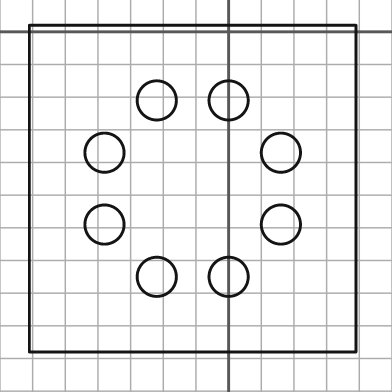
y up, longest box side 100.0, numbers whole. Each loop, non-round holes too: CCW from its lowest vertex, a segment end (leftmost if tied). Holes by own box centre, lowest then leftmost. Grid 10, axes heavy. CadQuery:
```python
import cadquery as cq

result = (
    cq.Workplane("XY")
    .moveTo(-61.0, -98.0)
    .lineTo(39.0, -98.0)
    .lineTo(39.0, 2.0)
    .lineTo(-61.0, 2.0)
    .close()
    .moveTo(-22.0, -75.0)
    .circle(6.0)
    .moveTo(0.0, -75.0)
    .circle(6.0)
    .moveTo(-38.0, -59.0)
    .circle(6.0)
    .moveTo(16.0, -59.0)
    .circle(6.0)
    .moveTo(-38.0, -37.0)
    .circle(6.0)
    .moveTo(16.0, -37.0)
    .circle(6.0)
    .moveTo(-22.0, -21.0)
    .circle(6.0)
    .moveTo(0.0, -21.0)
    .circle(6.0)
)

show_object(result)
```